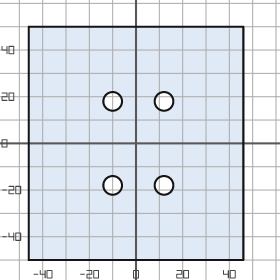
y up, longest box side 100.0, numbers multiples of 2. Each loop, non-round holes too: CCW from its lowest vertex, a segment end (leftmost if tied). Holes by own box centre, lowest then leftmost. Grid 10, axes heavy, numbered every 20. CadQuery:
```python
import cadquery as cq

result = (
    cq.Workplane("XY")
    .moveTo(-46.0, -50.0)
    .lineTo(46.0, -50.0)
    .lineTo(46.0, 50.0)
    .lineTo(-46.0, 50.0)
    .close()
    .moveTo(-10.0, -18.0)
    .circle(4.0)
    .moveTo(12.0, -18.0)
    .circle(4.0)
    .moveTo(-10.0, 18.0)
    .circle(4.0)
    .moveTo(12.0, 18.0)
    .circle(4.0)
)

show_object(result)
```